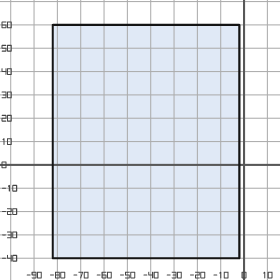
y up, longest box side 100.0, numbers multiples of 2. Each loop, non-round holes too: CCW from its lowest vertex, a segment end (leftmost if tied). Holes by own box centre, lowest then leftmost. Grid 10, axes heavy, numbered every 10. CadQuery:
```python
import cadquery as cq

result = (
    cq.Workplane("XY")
    .moveTo(-82.0, -40.0)
    .lineTo(-2.0, -40.0)
    .lineTo(-2.0, 60.0)
    .lineTo(-82.0, 60.0)
    .close()
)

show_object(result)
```